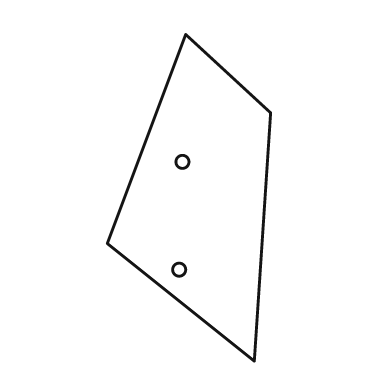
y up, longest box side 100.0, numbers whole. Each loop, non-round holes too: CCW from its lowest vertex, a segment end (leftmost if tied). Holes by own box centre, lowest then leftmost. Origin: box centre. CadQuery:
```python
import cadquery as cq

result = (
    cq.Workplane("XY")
    .moveTo(20.0, -50.0)
    .lineTo(25.0, 26.0)
    .lineTo(-1.0, 50.0)
    .lineTo(-25.0, -14.0)
    .close()
    .moveTo(-3.0, -22.0)
    .circle(2.0)
    .moveTo(-2.0, 11.0)
    .circle(2.0)
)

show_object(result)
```